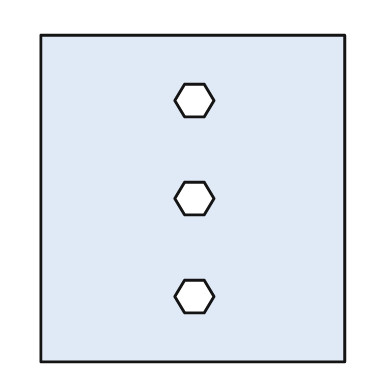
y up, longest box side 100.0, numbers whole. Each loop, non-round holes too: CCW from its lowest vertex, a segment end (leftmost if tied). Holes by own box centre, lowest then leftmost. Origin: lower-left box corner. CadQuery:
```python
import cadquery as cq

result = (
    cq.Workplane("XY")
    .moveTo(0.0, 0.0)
    .lineTo(93.0, 0.0)
    .lineTo(93.0, 100.0)
    .lineTo(0.0, 100.0)
    .close()
    .moveTo(44.0, 15.0)
    .lineTo(50.0, 15.0)
    .lineTo(53.0, 20.0)
    .lineTo(50.0, 25.0)
    .lineTo(44.0, 25.0)
    .lineTo(41.0, 20.0)
    .close()
    .moveTo(44.0, 45.0)
    .lineTo(50.0, 45.0)
    .lineTo(53.0, 50.0)
    .lineTo(50.0, 55.0)
    .lineTo(44.0, 55.0)
    .lineTo(41.0, 50.0)
    .close()
    .moveTo(44.0, 75.0)
    .lineTo(50.0, 75.0)
    .lineTo(53.0, 80.0)
    .lineTo(50.0, 85.0)
    .lineTo(44.0, 85.0)
    .lineTo(41.0, 80.0)
    .close()
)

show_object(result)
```